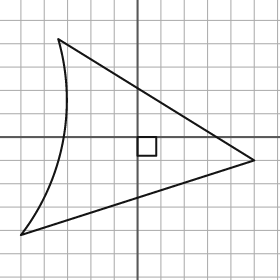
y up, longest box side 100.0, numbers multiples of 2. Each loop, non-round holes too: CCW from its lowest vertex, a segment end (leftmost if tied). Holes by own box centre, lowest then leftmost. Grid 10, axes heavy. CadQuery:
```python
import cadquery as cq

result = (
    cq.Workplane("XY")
    .moveTo(-50.0, -42.0)
    .lineTo(50.0, -10.0)
    .lineTo(-34.0, 42.0)
    .threePointArc((-32.0, -2.0), (-50.0, -42.0))
    .close()
    .moveTo(0.0, -8.0)
    .lineTo(8.0, -8.0)
    .lineTo(8.0, 0.0)
    .lineTo(0.0, 0.0)
    .close()
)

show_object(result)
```